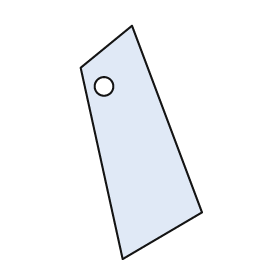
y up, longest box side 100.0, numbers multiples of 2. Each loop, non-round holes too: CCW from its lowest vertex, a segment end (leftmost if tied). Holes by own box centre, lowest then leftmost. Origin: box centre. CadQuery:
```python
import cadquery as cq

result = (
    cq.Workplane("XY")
    .moveTo(-8.0, -50.0)
    .lineTo(26.0, -30.0)
    .lineTo(-4.0, 50.0)
    .lineTo(-26.0, 32.0)
    .close()
    .moveTo(-16.0, 24.0)
    .circle(4.0)
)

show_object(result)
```